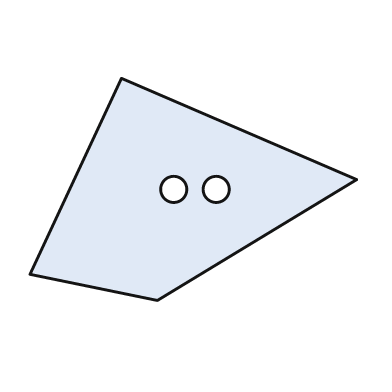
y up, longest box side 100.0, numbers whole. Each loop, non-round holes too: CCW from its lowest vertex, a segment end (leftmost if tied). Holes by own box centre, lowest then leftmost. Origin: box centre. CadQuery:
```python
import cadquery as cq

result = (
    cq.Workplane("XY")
    .moveTo(-11.0, -34.0)
    .lineTo(50.0, 3.0)
    .lineTo(-22.0, 34.0)
    .lineTo(-50.0, -26.0)
    .close()
    .moveTo(-6.0, 0.0)
    .circle(4.0)
    .moveTo(7.0, 0.0)
    .circle(4.0)
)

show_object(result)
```